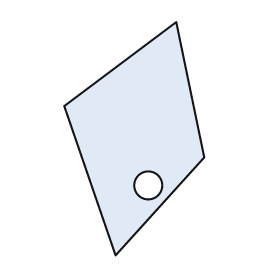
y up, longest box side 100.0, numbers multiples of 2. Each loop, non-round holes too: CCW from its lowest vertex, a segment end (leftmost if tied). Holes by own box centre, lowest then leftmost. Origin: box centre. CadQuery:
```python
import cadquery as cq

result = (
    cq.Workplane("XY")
    .moveTo(-8.0, -50.0)
    .lineTo(30.0, -8.0)
    .lineTo(18.0, 50.0)
    .lineTo(-30.0, 14.0)
    .close()
    .moveTo(6.0, -20.0)
    .circle(6.0)
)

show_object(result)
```